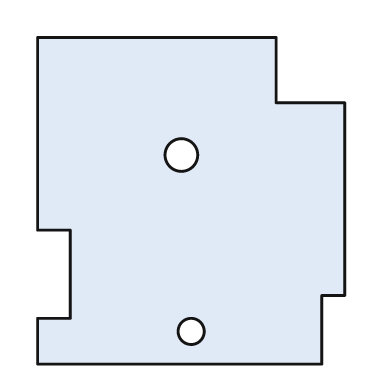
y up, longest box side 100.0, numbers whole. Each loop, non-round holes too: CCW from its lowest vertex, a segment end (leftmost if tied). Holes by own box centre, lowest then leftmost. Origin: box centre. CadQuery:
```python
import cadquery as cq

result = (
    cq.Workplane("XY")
    .moveTo(-47.0, -50.0)
    .lineTo(40.0, -50.0)
    .lineTo(40.0, -29.0)
    .lineTo(47.0, -29.0)
    .lineTo(47.0, 30.0)
    .lineTo(26.0, 30.0)
    .lineTo(26.0, 50.0)
    .lineTo(-47.0, 50.0)
    .lineTo(-47.0, -9.0)
    .lineTo(-37.0, -9.0)
    .lineTo(-37.0, -36.0)
    .lineTo(-47.0, -36.0)
    .close()
    .moveTo(0.0, -40.0)
    .circle(4.0)
    .moveTo(-3.0, 14.0)
    .circle(5.0)
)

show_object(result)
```